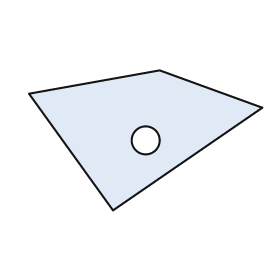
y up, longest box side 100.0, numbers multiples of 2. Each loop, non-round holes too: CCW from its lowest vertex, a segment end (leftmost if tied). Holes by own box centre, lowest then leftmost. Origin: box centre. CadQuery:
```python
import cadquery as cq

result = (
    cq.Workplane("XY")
    .moveTo(-14.0, -30.0)
    .lineTo(50.0, 14.0)
    .lineTo(6.0, 30.0)
    .lineTo(-50.0, 20.0)
    .close()
    .moveTo(0.0, 0.0)
    .circle(6.0)
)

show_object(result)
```